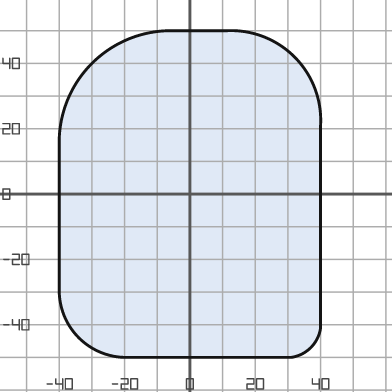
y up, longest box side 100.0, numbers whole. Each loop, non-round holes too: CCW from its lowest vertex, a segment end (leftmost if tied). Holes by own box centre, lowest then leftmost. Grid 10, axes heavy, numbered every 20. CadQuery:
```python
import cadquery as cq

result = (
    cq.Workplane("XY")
    .moveTo(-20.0, -50.0)
    .lineTo(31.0, -50.0)
    .threePointArc((37.0, -47.0), (40.0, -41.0))
    .lineTo(40.0, 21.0)
    .threePointArc((32.0, 42.0), (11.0, 50.0))
    .lineTo(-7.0, 50.0)
    .threePointArc((-30.0, 40.0), (-40.0, 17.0))
    .lineTo(-40.0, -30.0)
    .threePointArc((-34.0, -44.0), (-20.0, -50.0))
    .close()
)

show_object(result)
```